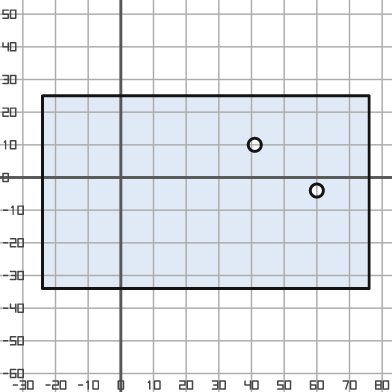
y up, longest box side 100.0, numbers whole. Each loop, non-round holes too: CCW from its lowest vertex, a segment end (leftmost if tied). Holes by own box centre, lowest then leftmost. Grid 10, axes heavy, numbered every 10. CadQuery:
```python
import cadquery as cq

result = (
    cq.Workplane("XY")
    .moveTo(-24.0, -34.0)
    .lineTo(76.0, -34.0)
    .lineTo(76.0, 25.0)
    .lineTo(-24.0, 25.0)
    .close()
    .moveTo(60.0, -4.0)
    .circle(2.0)
    .moveTo(41.0, 10.0)
    .circle(2.0)
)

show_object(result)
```